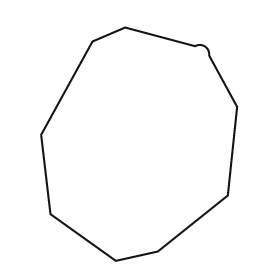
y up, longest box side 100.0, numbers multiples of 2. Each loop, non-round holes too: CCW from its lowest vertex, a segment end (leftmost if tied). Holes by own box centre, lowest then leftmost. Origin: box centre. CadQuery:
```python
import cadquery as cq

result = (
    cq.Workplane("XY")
    .moveTo(-10.0, -50.0)
    .lineTo(8.0, -46.0)
    .lineTo(38.0, -22.0)
    .lineTo(42.0, 16.0)
    .lineTo(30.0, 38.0)
    .threePointArc((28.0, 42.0), (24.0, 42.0))
    .lineTo(-6.0, 50.0)
    .lineTo(-20.0, 44.0)
    .lineTo(-42.0, 4.0)
    .lineTo(-38.0, -30.0)
    .close()
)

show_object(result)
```